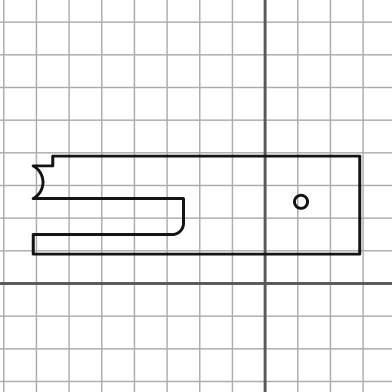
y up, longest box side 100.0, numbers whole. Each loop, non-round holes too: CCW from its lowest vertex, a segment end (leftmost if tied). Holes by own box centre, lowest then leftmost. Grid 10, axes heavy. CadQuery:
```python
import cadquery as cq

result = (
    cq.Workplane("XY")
    .moveTo(-71.0, 9.0)
    .lineTo(29.0, 9.0)
    .lineTo(29.0, 39.0)
    .lineTo(-65.0, 39.0)
    .lineTo(-65.0, 36.0)
    .lineTo(-71.0, 36.0)
    .threePointArc((-68.0, 31.0), (-71.0, 26.0))
    .lineTo(-25.0, 26.0)
    .lineTo(-25.0, 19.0)
    .threePointArc((-26.0, 16.0), (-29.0, 15.0))
    .lineTo(-71.0, 15.0)
    .close()
    .moveTo(11.0, 25.0)
    .circle(2.0)
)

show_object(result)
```